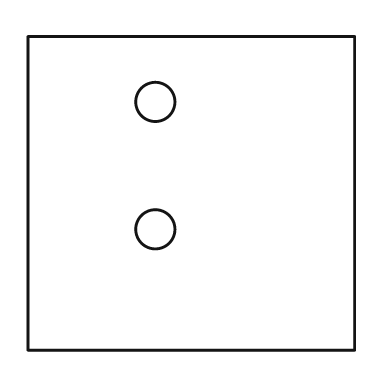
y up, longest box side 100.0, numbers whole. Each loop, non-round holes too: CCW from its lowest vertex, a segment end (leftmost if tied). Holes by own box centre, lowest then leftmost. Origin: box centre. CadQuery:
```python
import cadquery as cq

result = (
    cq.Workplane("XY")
    .moveTo(-50.0, -48.0)
    .lineTo(50.0, -48.0)
    .lineTo(50.0, 48.0)
    .lineTo(-50.0, 48.0)
    .close()
    .moveTo(-11.0, -11.0)
    .circle(6.0)
    .moveTo(-11.0, 28.0)
    .circle(6.0)
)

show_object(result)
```